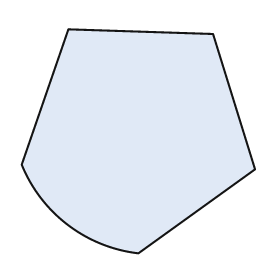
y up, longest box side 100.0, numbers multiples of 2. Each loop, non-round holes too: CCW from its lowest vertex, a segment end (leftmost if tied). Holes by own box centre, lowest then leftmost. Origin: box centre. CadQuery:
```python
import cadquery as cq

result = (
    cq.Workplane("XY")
    .moveTo(0.0, -48.0)
    .lineTo(50.0, -12.0)
    .lineTo(32.0, 46.0)
    .lineTo(-30.0, 48.0)
    .lineTo(-50.0, -10.0)
    .threePointArc((-30.0, -36.0), (0.0, -48.0))
    .close()
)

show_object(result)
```